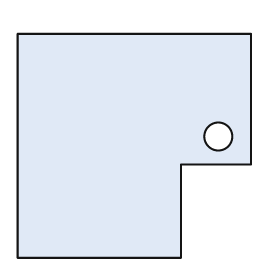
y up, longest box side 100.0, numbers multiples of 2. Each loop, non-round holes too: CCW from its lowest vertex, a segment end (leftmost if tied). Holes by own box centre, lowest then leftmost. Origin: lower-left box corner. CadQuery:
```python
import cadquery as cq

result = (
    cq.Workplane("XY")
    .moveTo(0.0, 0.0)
    .lineTo(70.0, 0.0)
    .lineTo(70.0, 40.0)
    .lineTo(100.0, 40.0)
    .lineTo(100.0, 96.0)
    .lineTo(0.0, 96.0)
    .close()
    .moveTo(86.0, 52.0)
    .circle(6.0)
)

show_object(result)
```